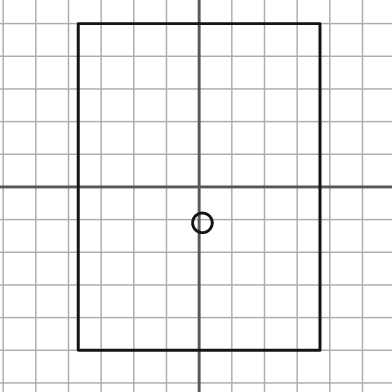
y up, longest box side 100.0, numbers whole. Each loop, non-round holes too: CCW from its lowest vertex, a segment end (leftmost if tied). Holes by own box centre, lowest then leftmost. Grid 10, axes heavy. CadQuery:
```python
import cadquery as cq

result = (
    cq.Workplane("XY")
    .moveTo(-37.0, -50.0)
    .lineTo(37.0, -50.0)
    .lineTo(37.0, 50.0)
    .lineTo(-37.0, 50.0)
    .close()
    .moveTo(1.0, -11.0)
    .circle(3.0)
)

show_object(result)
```